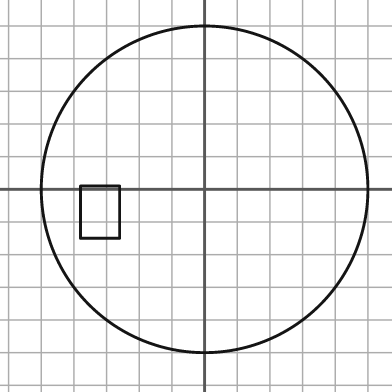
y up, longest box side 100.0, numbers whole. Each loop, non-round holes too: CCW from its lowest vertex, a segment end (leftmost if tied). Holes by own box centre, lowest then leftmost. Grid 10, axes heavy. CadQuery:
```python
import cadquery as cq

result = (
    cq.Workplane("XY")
    .moveTo(0.0, 0.0)
    .circle(50.0)
    .moveTo(-38.0, -15.0)
    .lineTo(-26.0, -15.0)
    .lineTo(-26.0, 1.0)
    .lineTo(-38.0, 1.0)
    .close()
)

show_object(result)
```